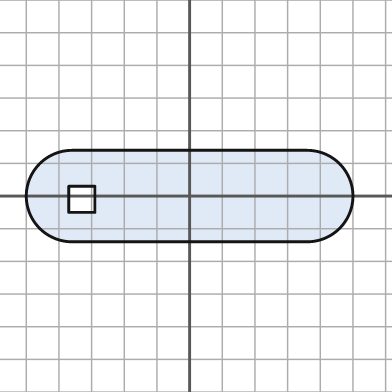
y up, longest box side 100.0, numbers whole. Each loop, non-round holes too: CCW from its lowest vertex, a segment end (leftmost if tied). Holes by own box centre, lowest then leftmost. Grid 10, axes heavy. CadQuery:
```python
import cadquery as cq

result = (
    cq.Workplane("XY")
    .moveTo(-36.0, -14.0)
    .lineTo(36.0, -14.0)
    .threePointArc((50.0, 0.0), (36.0, 14.0))
    .lineTo(-36.0, 14.0)
    .threePointArc((-50.0, 0.0), (-36.0, -14.0))
    .close()
    .moveTo(-37.0, -5.0)
    .lineTo(-29.0, -5.0)
    .lineTo(-29.0, 3.0)
    .lineTo(-37.0, 3.0)
    .close()
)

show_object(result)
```